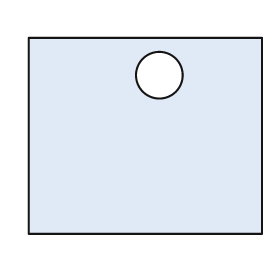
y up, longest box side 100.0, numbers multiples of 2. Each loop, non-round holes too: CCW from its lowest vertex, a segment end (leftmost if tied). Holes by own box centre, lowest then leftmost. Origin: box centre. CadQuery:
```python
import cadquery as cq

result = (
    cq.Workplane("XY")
    .moveTo(-50.0, -42.0)
    .lineTo(50.0, -42.0)
    .lineTo(50.0, 42.0)
    .lineTo(-50.0, 42.0)
    .close()
    .moveTo(6.0, 26.0)
    .circle(10.0)
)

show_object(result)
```